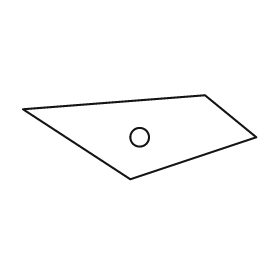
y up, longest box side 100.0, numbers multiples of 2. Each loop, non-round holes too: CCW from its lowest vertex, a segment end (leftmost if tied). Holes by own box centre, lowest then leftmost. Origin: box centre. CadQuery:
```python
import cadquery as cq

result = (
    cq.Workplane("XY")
    .moveTo(-4.0, -18.0)
    .lineTo(50.0, 0.0)
    .lineTo(28.0, 18.0)
    .lineTo(-50.0, 12.0)
    .close()
    .moveTo(0.0, 0.0)
    .circle(4.0)
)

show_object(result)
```